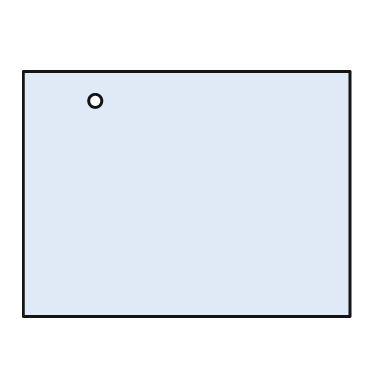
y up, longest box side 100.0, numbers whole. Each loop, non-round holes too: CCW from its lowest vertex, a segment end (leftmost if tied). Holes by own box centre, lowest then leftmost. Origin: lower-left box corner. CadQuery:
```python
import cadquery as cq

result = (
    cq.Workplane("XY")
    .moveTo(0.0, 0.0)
    .lineTo(100.0, 0.0)
    .lineTo(100.0, 75.0)
    .lineTo(0.0, 75.0)
    .close()
    .moveTo(22.0, 66.0)
    .circle(2.0)
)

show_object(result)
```